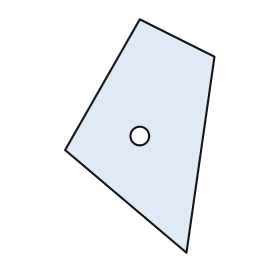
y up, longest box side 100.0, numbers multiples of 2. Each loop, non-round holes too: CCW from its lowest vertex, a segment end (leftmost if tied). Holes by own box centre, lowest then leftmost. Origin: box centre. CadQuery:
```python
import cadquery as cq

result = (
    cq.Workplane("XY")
    .moveTo(20.0, -50.0)
    .lineTo(32.0, 34.0)
    .lineTo(0.0, 50.0)
    .lineTo(-32.0, -6.0)
    .close()
    .moveTo(0.0, 0.0)
    .circle(4.0)
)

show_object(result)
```